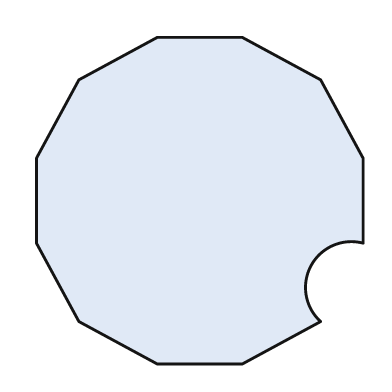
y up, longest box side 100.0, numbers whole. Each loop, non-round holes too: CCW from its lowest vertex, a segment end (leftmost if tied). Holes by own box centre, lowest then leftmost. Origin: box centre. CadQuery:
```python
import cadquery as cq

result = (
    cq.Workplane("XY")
    .moveTo(-13.0, -50.0)
    .lineTo(13.0, -50.0)
    .lineTo(37.0, -37.0)
    .threePointArc((34.0, -20.0), (50.0, -13.0))
    .lineTo(50.0, 13.0)
    .lineTo(37.0, 37.0)
    .lineTo(13.0, 50.0)
    .lineTo(-13.0, 50.0)
    .lineTo(-37.0, 37.0)
    .lineTo(-50.0, 13.0)
    .lineTo(-50.0, -13.0)
    .lineTo(-37.0, -37.0)
    .close()
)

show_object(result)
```